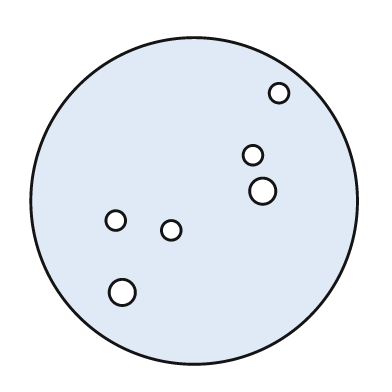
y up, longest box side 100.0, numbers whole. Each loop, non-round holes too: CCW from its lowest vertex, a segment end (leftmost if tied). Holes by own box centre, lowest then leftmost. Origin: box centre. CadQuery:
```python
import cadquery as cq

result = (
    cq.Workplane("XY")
    .moveTo(0.0, 0.0)
    .circle(50.0)
    .moveTo(-22.0, -28.0)
    .circle(4.0)
    .moveTo(-7.0, -9.0)
    .circle(3.0)
    .moveTo(-24.0, -6.0)
    .circle(3.0)
    .moveTo(21.0, 3.0)
    .circle(4.0)
    .moveTo(18.0, 14.0)
    .circle(3.0)
    .moveTo(26.0, 33.0)
    .circle(3.0)
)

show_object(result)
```